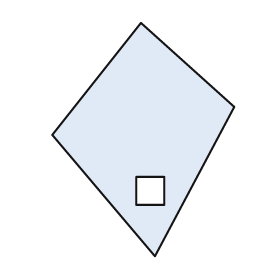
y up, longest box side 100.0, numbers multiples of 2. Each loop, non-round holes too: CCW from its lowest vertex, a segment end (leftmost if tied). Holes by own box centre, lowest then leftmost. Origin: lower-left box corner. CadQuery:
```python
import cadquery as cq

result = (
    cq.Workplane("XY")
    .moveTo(44.0, 0.0)
    .lineTo(78.0, 64.0)
    .lineTo(38.0, 100.0)
    .lineTo(0.0, 52.0)
    .close()
    .moveTo(36.0, 22.0)
    .lineTo(48.0, 22.0)
    .lineTo(48.0, 34.0)
    .lineTo(36.0, 34.0)
    .close()
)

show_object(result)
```